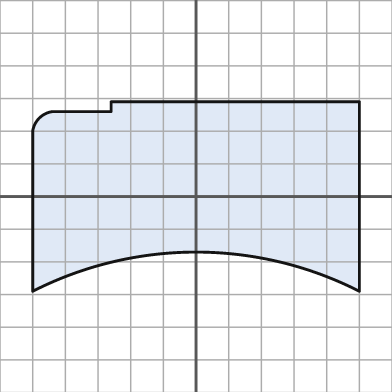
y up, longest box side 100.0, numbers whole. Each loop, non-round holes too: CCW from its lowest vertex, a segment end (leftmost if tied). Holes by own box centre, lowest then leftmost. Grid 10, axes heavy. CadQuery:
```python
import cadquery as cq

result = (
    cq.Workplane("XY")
    .moveTo(-50.0, -29.0)
    .threePointArc((0.0, -17.0), (50.0, -29.0))
    .lineTo(50.0, 29.0)
    .lineTo(-26.0, 29.0)
    .lineTo(-26.0, 26.0)
    .lineTo(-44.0, 26.0)
    .threePointArc((-48.0, 24.0), (-50.0, 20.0))
    .close()
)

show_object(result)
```